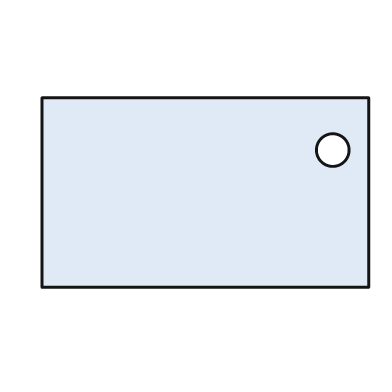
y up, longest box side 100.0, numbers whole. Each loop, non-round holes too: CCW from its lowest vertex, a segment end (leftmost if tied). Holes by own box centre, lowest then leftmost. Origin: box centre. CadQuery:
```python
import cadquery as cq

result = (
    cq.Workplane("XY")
    .moveTo(-50.0, -29.0)
    .lineTo(50.0, -29.0)
    .lineTo(50.0, 29.0)
    .lineTo(-50.0, 29.0)
    .close()
    .moveTo(39.0, 13.0)
    .circle(5.0)
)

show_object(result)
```